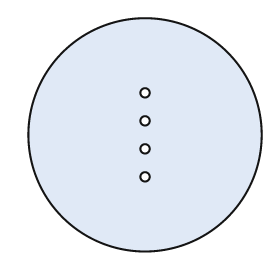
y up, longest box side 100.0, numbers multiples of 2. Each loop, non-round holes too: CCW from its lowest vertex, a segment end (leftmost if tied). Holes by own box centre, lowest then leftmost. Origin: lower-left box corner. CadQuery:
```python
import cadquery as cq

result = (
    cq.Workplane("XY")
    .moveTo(50.0, 50.0)
    .circle(50.0)
    .moveTo(50.0, 32.0)
    .circle(2.0)
    .moveTo(50.0, 44.0)
    .circle(2.0)
    .moveTo(50.0, 56.0)
    .circle(2.0)
    .moveTo(50.0, 68.0)
    .circle(2.0)
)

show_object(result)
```